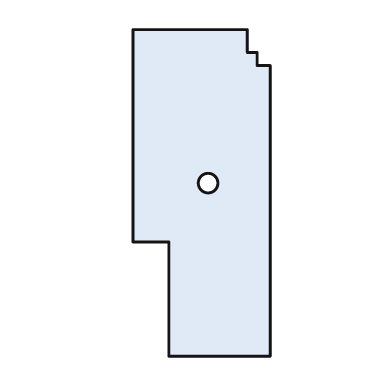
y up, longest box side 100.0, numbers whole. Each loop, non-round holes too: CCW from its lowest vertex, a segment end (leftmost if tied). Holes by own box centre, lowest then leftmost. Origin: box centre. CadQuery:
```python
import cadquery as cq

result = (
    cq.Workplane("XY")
    .moveTo(-10.0, -50.0)
    .lineTo(21.0, -50.0)
    .lineTo(21.0, 39.0)
    .lineTo(17.0, 39.0)
    .lineTo(17.0, 43.0)
    .lineTo(14.0, 43.0)
    .lineTo(14.0, 50.0)
    .lineTo(-21.0, 50.0)
    .lineTo(-21.0, -15.0)
    .lineTo(-10.0, -15.0)
    .close()
    .moveTo(2.0, 3.0)
    .circle(3.0)
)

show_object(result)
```